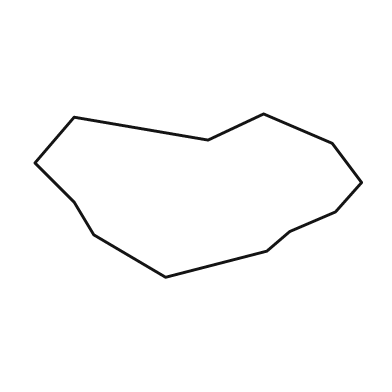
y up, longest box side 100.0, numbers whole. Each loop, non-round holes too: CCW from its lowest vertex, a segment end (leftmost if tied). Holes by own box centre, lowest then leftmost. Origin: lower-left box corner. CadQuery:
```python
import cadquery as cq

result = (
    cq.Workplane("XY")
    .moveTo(40.0, 0.0)
    .lineTo(71.0, 8.0)
    .lineTo(78.0, 14.0)
    .lineTo(92.0, 20.0)
    .lineTo(100.0, 29.0)
    .lineTo(91.0, 41.0)
    .lineTo(70.0, 50.0)
    .lineTo(53.0, 42.0)
    .lineTo(12.0, 49.0)
    .lineTo(0.0, 35.0)
    .lineTo(12.0, 23.0)
    .lineTo(18.0, 13.0)
    .close()
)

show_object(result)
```